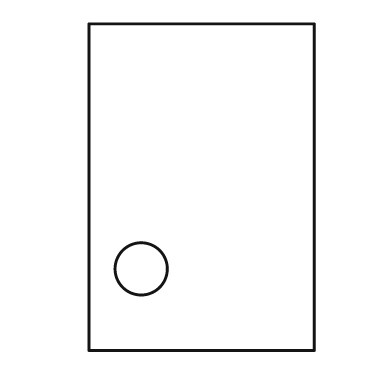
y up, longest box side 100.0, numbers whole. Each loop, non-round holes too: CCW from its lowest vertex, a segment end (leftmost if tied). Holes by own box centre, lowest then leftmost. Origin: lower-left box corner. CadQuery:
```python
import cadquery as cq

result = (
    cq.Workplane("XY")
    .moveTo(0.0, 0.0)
    .lineTo(69.0, 0.0)
    .lineTo(69.0, 100.0)
    .lineTo(0.0, 100.0)
    .close()
    .moveTo(16.0, 25.0)
    .circle(8.0)
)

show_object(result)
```